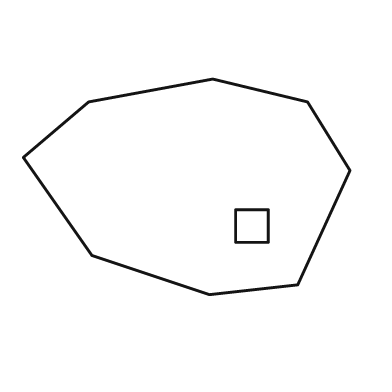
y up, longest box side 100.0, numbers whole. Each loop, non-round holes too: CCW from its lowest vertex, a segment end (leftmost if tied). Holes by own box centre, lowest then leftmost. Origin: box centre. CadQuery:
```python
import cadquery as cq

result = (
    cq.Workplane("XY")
    .moveTo(7.0, -33.0)
    .lineTo(34.0, -30.0)
    .lineTo(50.0, 5.0)
    .lineTo(37.0, 26.0)
    .lineTo(8.0, 33.0)
    .lineTo(-30.0, 26.0)
    .lineTo(-50.0, 9.0)
    .lineTo(-29.0, -21.0)
    .close()
    .moveTo(15.0, -17.0)
    .lineTo(25.0, -17.0)
    .lineTo(25.0, -7.0)
    .lineTo(15.0, -7.0)
    .close()
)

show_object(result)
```